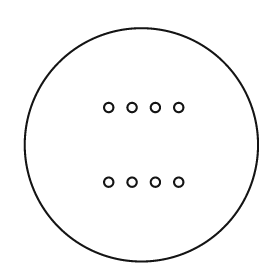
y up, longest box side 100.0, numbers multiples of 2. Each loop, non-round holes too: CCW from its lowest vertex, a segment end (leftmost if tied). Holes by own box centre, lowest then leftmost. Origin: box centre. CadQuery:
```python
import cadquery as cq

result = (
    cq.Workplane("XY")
    .moveTo(0.0, 0.0)
    .circle(50.0)
    .moveTo(-14.0, -16.0)
    .circle(2.0)
    .moveTo(-4.0, -16.0)
    .circle(2.0)
    .moveTo(6.0, -16.0)
    .circle(2.0)
    .moveTo(16.0, -16.0)
    .circle(2.0)
    .moveTo(-14.0, 16.0)
    .circle(2.0)
    .moveTo(-4.0, 16.0)
    .circle(2.0)
    .moveTo(6.0, 16.0)
    .circle(2.0)
    .moveTo(16.0, 16.0)
    .circle(2.0)
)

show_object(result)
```